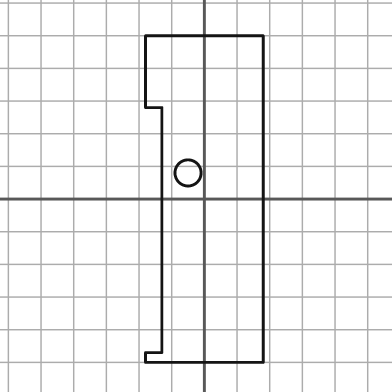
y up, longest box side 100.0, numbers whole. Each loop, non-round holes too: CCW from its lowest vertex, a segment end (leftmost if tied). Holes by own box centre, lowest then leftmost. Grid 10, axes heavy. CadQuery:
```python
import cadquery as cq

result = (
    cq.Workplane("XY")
    .moveTo(-18.0, -50.0)
    .lineTo(18.0, -50.0)
    .lineTo(18.0, 50.0)
    .lineTo(-18.0, 50.0)
    .lineTo(-18.0, 28.0)
    .lineTo(-13.0, 28.0)
    .lineTo(-13.0, -47.0)
    .lineTo(-18.0, -47.0)
    .close()
    .moveTo(-5.0, 8.0)
    .circle(4.0)
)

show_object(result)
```